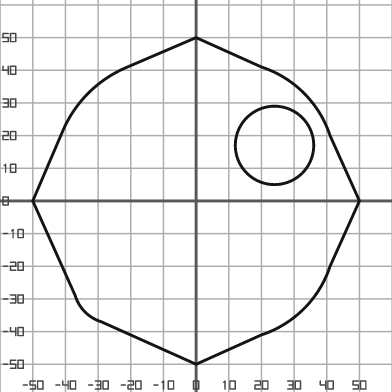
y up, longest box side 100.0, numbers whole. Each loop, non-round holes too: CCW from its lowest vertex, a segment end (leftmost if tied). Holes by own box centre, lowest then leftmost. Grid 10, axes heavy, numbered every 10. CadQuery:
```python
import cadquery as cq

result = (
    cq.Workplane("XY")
    .moveTo(0.0, -50.0)
    .lineTo(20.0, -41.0)
    .threePointArc((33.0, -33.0), (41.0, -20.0))
    .lineTo(50.0, 0.0)
    .lineTo(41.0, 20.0)
    .threePointArc((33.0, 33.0), (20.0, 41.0))
    .lineTo(0.0, 50.0)
    .lineTo(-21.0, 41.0)
    .threePointArc((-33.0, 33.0), (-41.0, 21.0))
    .lineTo(-50.0, 0.0)
    .lineTo(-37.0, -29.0)
    .threePointArc((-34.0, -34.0), (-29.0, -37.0))
    .close()
    .moveTo(24.0, 17.0)
    .circle(12.0)
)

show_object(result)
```